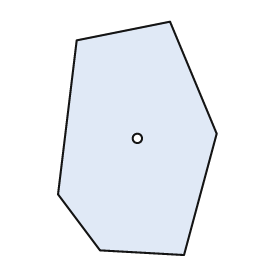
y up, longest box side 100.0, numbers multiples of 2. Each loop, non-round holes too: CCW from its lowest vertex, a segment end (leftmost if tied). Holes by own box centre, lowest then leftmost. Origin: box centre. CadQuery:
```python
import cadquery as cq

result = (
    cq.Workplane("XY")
    .moveTo(20.0, -50.0)
    .lineTo(34.0, 2.0)
    .lineTo(14.0, 50.0)
    .lineTo(-26.0, 42.0)
    .lineTo(-34.0, -24.0)
    .lineTo(-16.0, -48.0)
    .close()
    .moveTo(0.0, 0.0)
    .circle(2.0)
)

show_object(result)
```